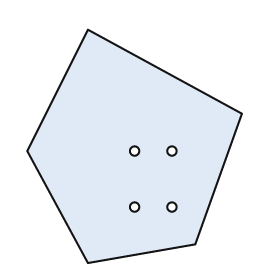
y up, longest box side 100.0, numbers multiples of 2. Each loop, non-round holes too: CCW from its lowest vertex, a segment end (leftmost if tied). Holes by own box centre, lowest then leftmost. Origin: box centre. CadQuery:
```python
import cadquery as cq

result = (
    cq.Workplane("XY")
    .moveTo(-20.0, -50.0)
    .lineTo(26.0, -42.0)
    .lineTo(46.0, 14.0)
    .lineTo(-20.0, 50.0)
    .lineTo(-46.0, -2.0)
    .close()
    .moveTo(0.0, -26.0)
    .circle(2.0)
    .moveTo(16.0, -26.0)
    .circle(2.0)
    .moveTo(0.0, -2.0)
    .circle(2.0)
    .moveTo(16.0, -2.0)
    .circle(2.0)
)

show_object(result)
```